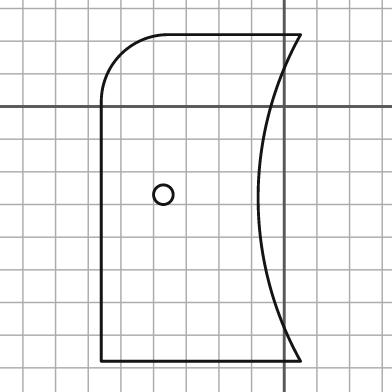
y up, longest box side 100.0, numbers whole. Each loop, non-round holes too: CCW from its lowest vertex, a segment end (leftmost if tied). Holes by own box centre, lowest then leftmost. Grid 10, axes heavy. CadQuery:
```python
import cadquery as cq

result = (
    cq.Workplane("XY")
    .moveTo(-56.0, -78.0)
    .lineTo(5.0, -78.0)
    .threePointArc((-8.0, -28.0), (5.0, 22.0))
    .lineTo(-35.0, 22.0)
    .threePointArc((-50.0, 16.0), (-56.0, 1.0))
    .close()
    .moveTo(-37.0, -27.0)
    .circle(3.0)
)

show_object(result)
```